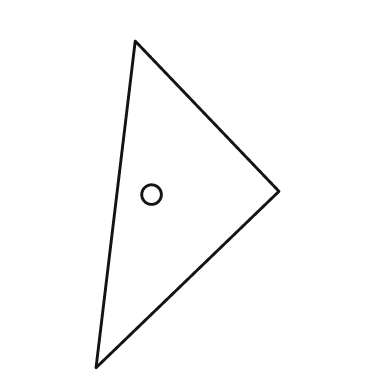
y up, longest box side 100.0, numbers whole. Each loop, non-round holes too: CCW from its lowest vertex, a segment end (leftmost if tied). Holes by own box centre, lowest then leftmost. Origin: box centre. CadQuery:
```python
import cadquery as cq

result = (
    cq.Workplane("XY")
    .moveTo(-28.0, -50.0)
    .lineTo(28.0, 4.0)
    .lineTo(-16.0, 50.0)
    .close()
    .moveTo(-11.0, 3.0)
    .circle(3.0)
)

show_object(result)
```